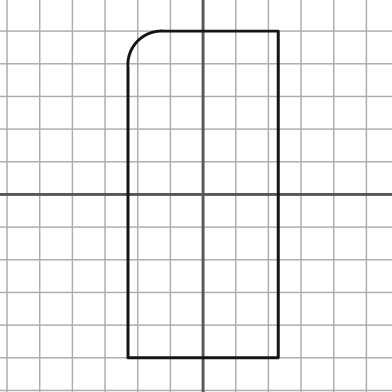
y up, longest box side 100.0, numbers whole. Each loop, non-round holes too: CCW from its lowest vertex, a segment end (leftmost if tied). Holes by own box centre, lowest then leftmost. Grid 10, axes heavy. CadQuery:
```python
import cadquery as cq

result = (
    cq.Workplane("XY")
    .moveTo(-23.0, -50.0)
    .lineTo(23.0, -50.0)
    .lineTo(23.0, 50.0)
    .lineTo(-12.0, 50.0)
    .threePointArc((-20.0, 47.0), (-23.0, 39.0))
    .close()
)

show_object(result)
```